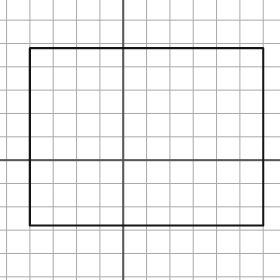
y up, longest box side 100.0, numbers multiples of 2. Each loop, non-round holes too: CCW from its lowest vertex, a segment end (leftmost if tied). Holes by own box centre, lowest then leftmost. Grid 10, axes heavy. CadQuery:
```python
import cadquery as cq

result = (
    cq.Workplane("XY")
    .moveTo(-40.0, -28.0)
    .lineTo(60.0, -28.0)
    .lineTo(60.0, 48.0)
    .lineTo(-40.0, 48.0)
    .close()
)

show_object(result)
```